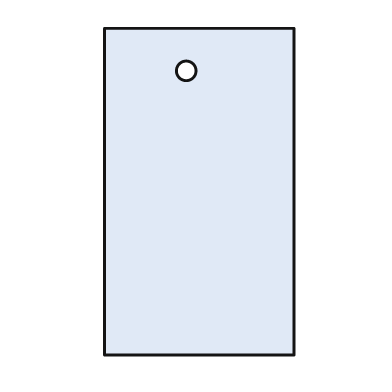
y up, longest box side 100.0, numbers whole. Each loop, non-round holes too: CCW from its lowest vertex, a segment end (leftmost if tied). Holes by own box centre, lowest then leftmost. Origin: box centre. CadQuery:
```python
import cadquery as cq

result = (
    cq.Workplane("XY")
    .moveTo(-29.0, -50.0)
    .lineTo(29.0, -50.0)
    .lineTo(29.0, 50.0)
    .lineTo(-29.0, 50.0)
    .close()
    .moveTo(-4.0, 37.0)
    .circle(3.0)
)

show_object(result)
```